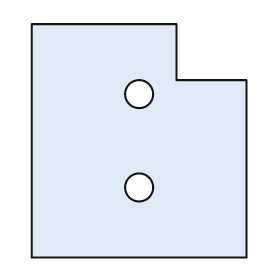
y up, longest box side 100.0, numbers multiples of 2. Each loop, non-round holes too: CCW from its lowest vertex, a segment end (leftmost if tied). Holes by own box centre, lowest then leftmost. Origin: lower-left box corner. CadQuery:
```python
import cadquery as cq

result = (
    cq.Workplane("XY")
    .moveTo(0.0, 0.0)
    .lineTo(92.0, 0.0)
    .lineTo(92.0, 76.0)
    .lineTo(62.0, 76.0)
    .lineTo(62.0, 100.0)
    .lineTo(0.0, 100.0)
    .close()
    .moveTo(46.0, 30.0)
    .circle(6.0)
    .moveTo(46.0, 70.0)
    .circle(6.0)
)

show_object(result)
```